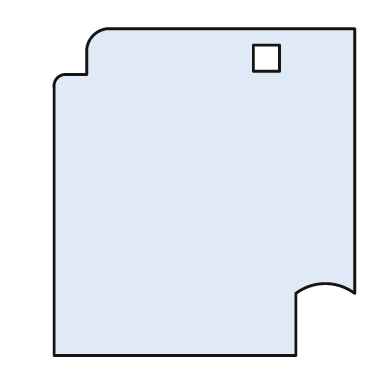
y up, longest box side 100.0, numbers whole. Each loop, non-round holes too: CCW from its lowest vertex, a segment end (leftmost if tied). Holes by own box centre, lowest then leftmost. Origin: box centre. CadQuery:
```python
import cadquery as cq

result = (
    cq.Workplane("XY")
    .moveTo(-46.0, -50.0)
    .lineTo(28.0, -50.0)
    .lineTo(28.0, -31.0)
    .threePointArc((37.0, -28.0), (46.0, -31.0))
    .lineTo(46.0, 50.0)
    .lineTo(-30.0, 50.0)
    .threePointArc((-34.0, 48.0), (-36.0, 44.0))
    .lineTo(-36.0, 36.0)
    .lineTo(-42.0, 36.0)
    .threePointArc((-45.0, 35.0), (-46.0, 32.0))
    .close()
    .moveTo(15.0, 37.0)
    .lineTo(23.0, 37.0)
    .lineTo(23.0, 45.0)
    .lineTo(15.0, 45.0)
    .close()
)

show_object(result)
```